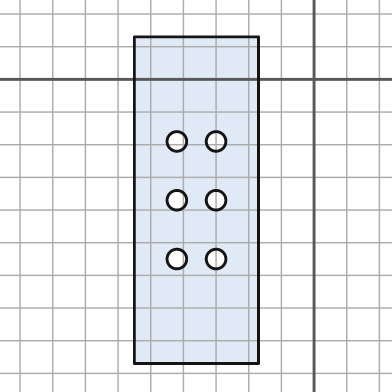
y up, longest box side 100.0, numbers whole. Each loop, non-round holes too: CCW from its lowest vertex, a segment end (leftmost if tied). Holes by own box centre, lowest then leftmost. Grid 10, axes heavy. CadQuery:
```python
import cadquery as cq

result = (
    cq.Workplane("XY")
    .moveTo(-55.0, -87.0)
    .lineTo(-17.0, -87.0)
    .lineTo(-17.0, 13.0)
    .lineTo(-55.0, 13.0)
    .close()
    .moveTo(-42.0, -55.0)
    .circle(3.0)
    .moveTo(-30.0, -55.0)
    .circle(3.0)
    .moveTo(-42.0, -37.0)
    .circle(3.0)
    .moveTo(-30.0, -37.0)
    .circle(3.0)
    .moveTo(-42.0, -19.0)
    .circle(3.0)
    .moveTo(-30.0, -19.0)
    .circle(3.0)
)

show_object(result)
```